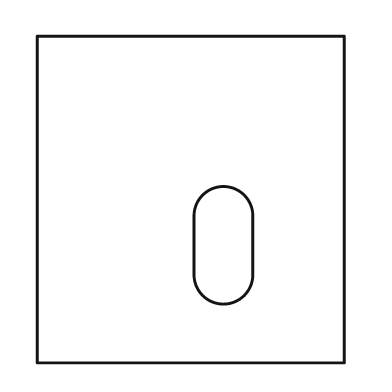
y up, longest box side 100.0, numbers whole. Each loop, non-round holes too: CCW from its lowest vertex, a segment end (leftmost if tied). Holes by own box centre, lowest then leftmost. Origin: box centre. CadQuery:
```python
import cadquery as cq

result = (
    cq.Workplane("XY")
    .moveTo(-47.0, -50.0)
    .lineTo(47.0, -50.0)
    .lineTo(47.0, 50.0)
    .lineTo(-47.0, 50.0)
    .close()
    .moveTo(1.0, -23.0)
    .threePointArc((10.0, -32.0), (19.0, -23.0))
    .lineTo(19.0, -5.0)
    .threePointArc((10.0, 4.0), (1.0, -5.0))
    .close()
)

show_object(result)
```